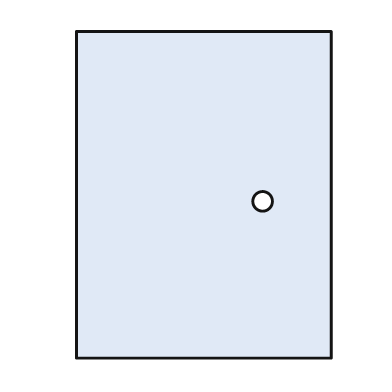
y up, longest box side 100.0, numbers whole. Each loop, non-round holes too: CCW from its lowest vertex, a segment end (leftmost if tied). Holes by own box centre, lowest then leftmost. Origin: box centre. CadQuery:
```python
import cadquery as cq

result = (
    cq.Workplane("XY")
    .moveTo(-39.0, -50.0)
    .lineTo(39.0, -50.0)
    .lineTo(39.0, 50.0)
    .lineTo(-39.0, 50.0)
    .close()
    .moveTo(18.0, -2.0)
    .circle(3.0)
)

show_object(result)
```